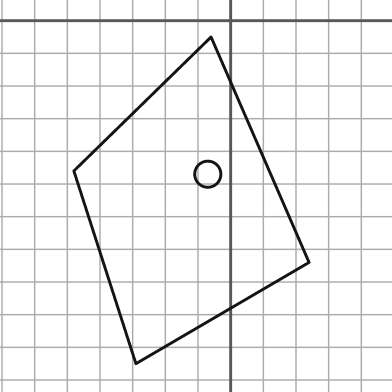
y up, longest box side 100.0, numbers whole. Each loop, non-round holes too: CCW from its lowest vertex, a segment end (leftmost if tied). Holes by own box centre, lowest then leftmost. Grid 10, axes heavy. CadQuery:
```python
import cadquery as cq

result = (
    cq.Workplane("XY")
    .moveTo(-29.0, -105.0)
    .lineTo(24.0, -74.0)
    .lineTo(-6.0, -5.0)
    .lineTo(-48.0, -46.0)
    .close()
    .moveTo(-7.0, -47.0)
    .circle(4.0)
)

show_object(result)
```